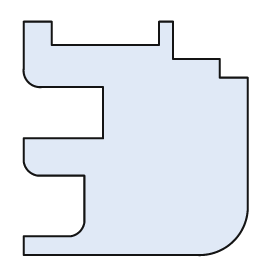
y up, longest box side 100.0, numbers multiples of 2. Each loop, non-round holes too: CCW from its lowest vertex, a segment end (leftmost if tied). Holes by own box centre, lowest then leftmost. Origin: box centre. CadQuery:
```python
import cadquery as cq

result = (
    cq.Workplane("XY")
    .moveTo(-48.0, -50.0)
    .lineTo(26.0, -50.0)
    .threePointArc((42.0, -44.0), (48.0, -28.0))
    .lineTo(48.0, 26.0)
    .lineTo(36.0, 26.0)
    .lineTo(36.0, 34.0)
    .lineTo(16.0, 34.0)
    .lineTo(16.0, 50.0)
    .lineTo(10.0, 50.0)
    .lineTo(10.0, 40.0)
    .lineTo(-36.0, 40.0)
    .lineTo(-36.0, 50.0)
    .lineTo(-48.0, 50.0)
    .lineTo(-48.0, 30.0)
    .threePointArc((-46.0, 24.0), (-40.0, 22.0))
    .lineTo(-14.0, 22.0)
    .lineTo(-14.0, 0.0)
    .lineTo(-48.0, 0.0)
    .lineTo(-48.0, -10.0)
    .threePointArc((-46.0, -14.0), (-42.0, -16.0))
    .lineTo(-22.0, -16.0)
    .lineTo(-22.0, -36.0)
    .threePointArc((-24.0, -40.0), (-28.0, -42.0))
    .lineTo(-48.0, -42.0)
    .close()
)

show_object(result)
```